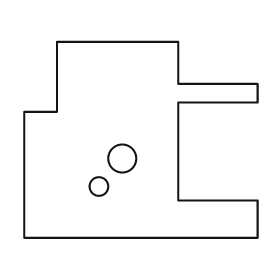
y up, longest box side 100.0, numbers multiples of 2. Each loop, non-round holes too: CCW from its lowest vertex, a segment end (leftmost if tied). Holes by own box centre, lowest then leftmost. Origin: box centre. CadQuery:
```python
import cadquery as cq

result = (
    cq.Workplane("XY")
    .moveTo(-50.0, -42.0)
    .lineTo(50.0, -42.0)
    .lineTo(50.0, -26.0)
    .lineTo(16.0, -26.0)
    .lineTo(16.0, 16.0)
    .lineTo(50.0, 16.0)
    .lineTo(50.0, 24.0)
    .lineTo(16.0, 24.0)
    .lineTo(16.0, 42.0)
    .lineTo(-36.0, 42.0)
    .lineTo(-36.0, 12.0)
    .lineTo(-50.0, 12.0)
    .close()
    .moveTo(-18.0, -20.0)
    .circle(4.0)
    .moveTo(-8.0, -8.0)
    .circle(6.0)
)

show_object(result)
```